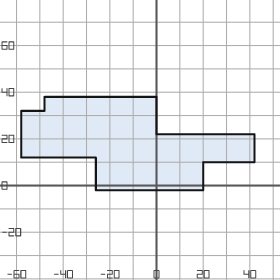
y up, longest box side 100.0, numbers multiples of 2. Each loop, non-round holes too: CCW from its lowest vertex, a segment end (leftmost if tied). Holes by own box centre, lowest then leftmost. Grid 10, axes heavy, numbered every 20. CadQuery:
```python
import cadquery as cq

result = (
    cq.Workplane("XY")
    .moveTo(-26.0, -2.0)
    .lineTo(20.0, -2.0)
    .lineTo(20.0, 10.0)
    .lineTo(42.0, 10.0)
    .lineTo(42.0, 22.0)
    .lineTo(0.0, 22.0)
    .lineTo(0.0, 38.0)
    .lineTo(-48.0, 38.0)
    .lineTo(-48.0, 32.0)
    .lineTo(-58.0, 32.0)
    .lineTo(-58.0, 12.0)
    .lineTo(-26.0, 12.0)
    .close()
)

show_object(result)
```